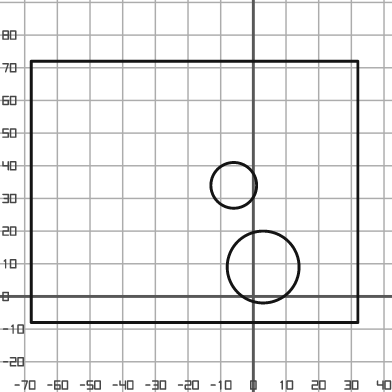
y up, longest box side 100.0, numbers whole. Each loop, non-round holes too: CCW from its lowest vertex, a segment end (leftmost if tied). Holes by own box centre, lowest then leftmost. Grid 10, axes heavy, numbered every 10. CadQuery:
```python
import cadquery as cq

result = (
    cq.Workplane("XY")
    .moveTo(-68.0, -8.0)
    .lineTo(32.0, -8.0)
    .lineTo(32.0, 72.0)
    .lineTo(-68.0, 72.0)
    .close()
    .moveTo(3.0, 9.0)
    .circle(11.0)
    .moveTo(-6.0, 34.0)
    .circle(7.0)
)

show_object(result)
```